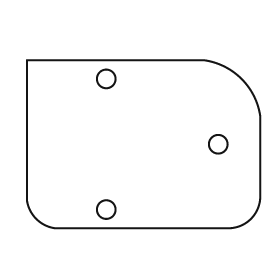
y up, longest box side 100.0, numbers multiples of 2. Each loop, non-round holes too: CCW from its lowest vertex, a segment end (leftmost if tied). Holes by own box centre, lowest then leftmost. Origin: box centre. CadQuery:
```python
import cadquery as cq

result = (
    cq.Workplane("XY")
    .moveTo(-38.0, -36.0)
    .lineTo(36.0, -36.0)
    .threePointArc((46.0, -32.0), (50.0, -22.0))
    .lineTo(50.0, 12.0)
    .threePointArc((42.0, 28.0), (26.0, 36.0))
    .lineTo(-50.0, 36.0)
    .lineTo(-50.0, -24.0)
    .threePointArc((-46.0, -32.0), (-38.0, -36.0))
    .close()
    .moveTo(-16.0, -28.0)
    .circle(4.0)
    .moveTo(32.0, 0.0)
    .circle(4.0)
    .moveTo(-16.0, 28.0)
    .circle(4.0)
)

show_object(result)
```